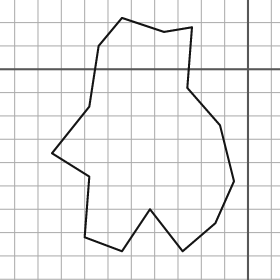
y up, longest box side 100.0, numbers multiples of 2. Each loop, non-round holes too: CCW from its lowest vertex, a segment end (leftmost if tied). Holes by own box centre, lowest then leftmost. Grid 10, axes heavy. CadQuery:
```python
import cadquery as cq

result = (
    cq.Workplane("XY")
    .moveTo(-54.0, -78.0)
    .lineTo(-42.0, -60.0)
    .lineTo(-28.0, -78.0)
    .lineTo(-14.0, -66.0)
    .lineTo(-6.0, -48.0)
    .lineTo(-12.0, -24.0)
    .lineTo(-26.0, -8.0)
    .lineTo(-24.0, 18.0)
    .lineTo(-36.0, 16.0)
    .lineTo(-54.0, 22.0)
    .lineTo(-64.0, 10.0)
    .lineTo(-68.0, -16.0)
    .lineTo(-84.0, -36.0)
    .lineTo(-68.0, -46.0)
    .lineTo(-70.0, -72.0)
    .close()
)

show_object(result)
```